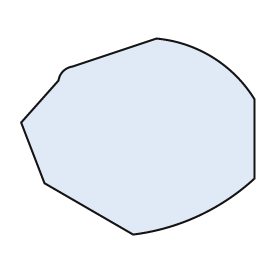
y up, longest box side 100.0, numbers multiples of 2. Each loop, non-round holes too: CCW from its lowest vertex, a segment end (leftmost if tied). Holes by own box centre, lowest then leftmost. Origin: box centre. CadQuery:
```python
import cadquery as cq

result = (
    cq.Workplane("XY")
    .moveTo(-2.0, -42.0)
    .threePointArc((26.0, -34.0), (50.0, -18.0))
    .lineTo(50.0, 16.0)
    .threePointArc((32.0, 34.0), (8.0, 42.0))
    .lineTo(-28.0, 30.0)
    .threePointArc((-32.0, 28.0), (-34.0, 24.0))
    .lineTo(-50.0, 6.0)
    .lineTo(-40.0, -20.0)
    .close()
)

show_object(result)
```